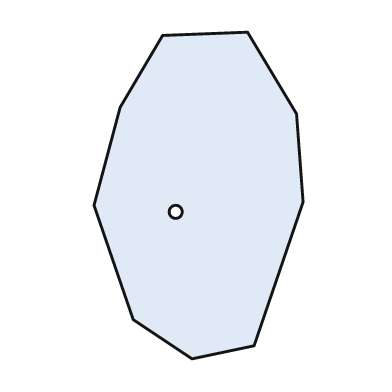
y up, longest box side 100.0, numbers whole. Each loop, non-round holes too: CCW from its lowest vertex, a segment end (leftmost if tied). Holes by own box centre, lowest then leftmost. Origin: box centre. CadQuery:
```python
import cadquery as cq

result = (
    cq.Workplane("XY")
    .moveTo(-2.0, -50.0)
    .lineTo(17.0, -46.0)
    .lineTo(32.0, -2.0)
    .lineTo(30.0, 25.0)
    .lineTo(15.0, 50.0)
    .lineTo(-11.0, 49.0)
    .lineTo(-24.0, 27.0)
    .lineTo(-32.0, -3.0)
    .lineTo(-20.0, -38.0)
    .close()
    .moveTo(-7.0, -5.0)
    .circle(2.0)
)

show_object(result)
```